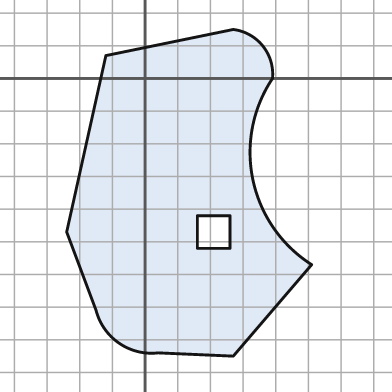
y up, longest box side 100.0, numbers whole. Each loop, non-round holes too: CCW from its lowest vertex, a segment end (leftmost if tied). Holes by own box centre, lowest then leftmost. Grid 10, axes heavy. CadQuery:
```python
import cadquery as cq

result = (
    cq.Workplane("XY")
    .moveTo(27.0, -85.0)
    .lineTo(51.0, -57.0)
    .threePointArc((33.0, -31.0), (39.0, 0.0))
    .threePointArc((36.0, 10.0), (27.0, 15.0))
    .lineTo(-12.0, 7.0)
    .lineTo(-24.0, -47.0)
    .lineTo(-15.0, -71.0)
    .threePointArc((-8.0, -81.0), (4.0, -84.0))
    .close()
    .moveTo(16.0, -52.0)
    .lineTo(26.0, -52.0)
    .lineTo(26.0, -42.0)
    .lineTo(16.0, -42.0)
    .close()
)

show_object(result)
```